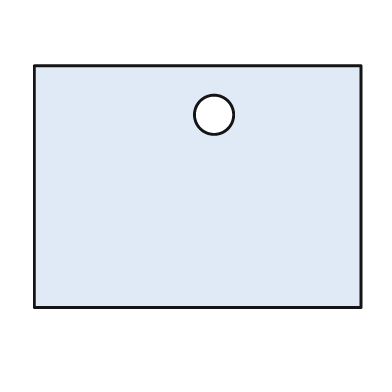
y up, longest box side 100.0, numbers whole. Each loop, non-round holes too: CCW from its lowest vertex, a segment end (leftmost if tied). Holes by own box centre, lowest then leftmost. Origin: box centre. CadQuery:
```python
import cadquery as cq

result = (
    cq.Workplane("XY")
    .moveTo(-50.0, -37.0)
    .lineTo(50.0, -37.0)
    .lineTo(50.0, 37.0)
    .lineTo(-50.0, 37.0)
    .close()
    .moveTo(5.0, 22.0)
    .circle(6.0)
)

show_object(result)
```